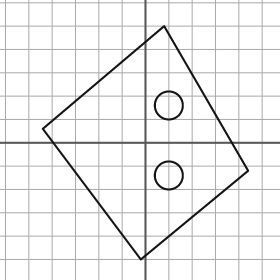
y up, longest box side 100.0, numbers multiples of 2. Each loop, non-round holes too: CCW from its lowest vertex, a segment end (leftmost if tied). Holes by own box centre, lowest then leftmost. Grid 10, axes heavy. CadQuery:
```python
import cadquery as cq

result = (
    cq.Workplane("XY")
    .moveTo(-2.0, -50.0)
    .lineTo(44.0, -12.0)
    .lineTo(8.0, 50.0)
    .lineTo(-44.0, 6.0)
    .close()
    .moveTo(10.0, -14.0)
    .circle(6.0)
    .moveTo(10.0, 16.0)
    .circle(6.0)
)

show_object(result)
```